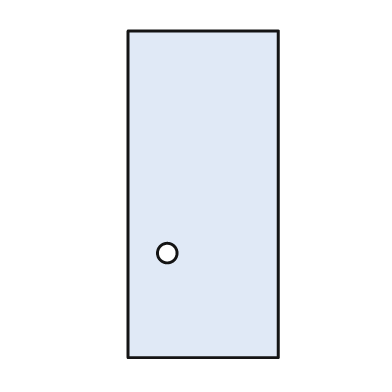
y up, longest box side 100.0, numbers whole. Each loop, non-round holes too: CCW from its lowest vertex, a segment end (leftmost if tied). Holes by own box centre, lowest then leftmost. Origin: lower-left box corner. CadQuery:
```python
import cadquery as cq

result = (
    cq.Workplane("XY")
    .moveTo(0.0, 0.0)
    .lineTo(46.0, 0.0)
    .lineTo(46.0, 100.0)
    .lineTo(0.0, 100.0)
    .close()
    .moveTo(12.0, 32.0)
    .circle(3.0)
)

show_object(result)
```